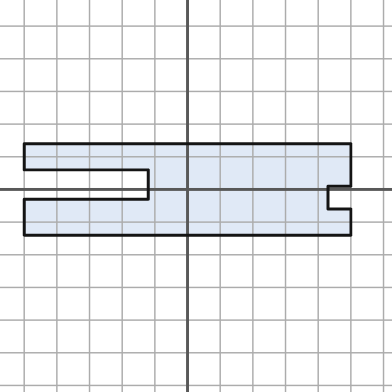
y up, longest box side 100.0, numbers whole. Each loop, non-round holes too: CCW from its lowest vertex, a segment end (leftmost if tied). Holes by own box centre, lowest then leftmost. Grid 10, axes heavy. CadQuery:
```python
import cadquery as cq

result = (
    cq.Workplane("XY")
    .moveTo(-50.0, -14.0)
    .lineTo(50.0, -14.0)
    .lineTo(50.0, -6.0)
    .lineTo(43.0, -6.0)
    .lineTo(43.0, 1.0)
    .lineTo(50.0, 1.0)
    .lineTo(50.0, 14.0)
    .lineTo(-50.0, 14.0)
    .lineTo(-50.0, 6.0)
    .lineTo(-12.0, 6.0)
    .lineTo(-12.0, -3.0)
    .lineTo(-50.0, -3.0)
    .close()
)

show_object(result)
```